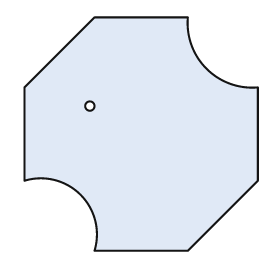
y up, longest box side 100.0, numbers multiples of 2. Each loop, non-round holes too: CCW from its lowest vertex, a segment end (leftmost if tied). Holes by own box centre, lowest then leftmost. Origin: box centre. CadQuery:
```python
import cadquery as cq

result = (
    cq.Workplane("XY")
    .moveTo(-20.0, -50.0)
    .lineTo(20.0, -50.0)
    .lineTo(50.0, -20.0)
    .lineTo(50.0, 20.0)
    .threePointArc((28.0, 28.0), (20.0, 50.0))
    .lineTo(-20.0, 50.0)
    .lineTo(-50.0, 20.0)
    .lineTo(-50.0, -20.0)
    .threePointArc((-26.0, -26.0), (-20.0, -50.0))
    .close()
    .moveTo(-22.0, 12.0)
    .circle(2.0)
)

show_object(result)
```